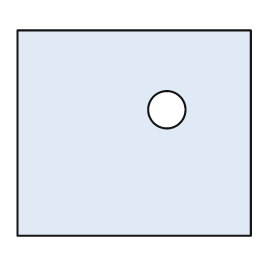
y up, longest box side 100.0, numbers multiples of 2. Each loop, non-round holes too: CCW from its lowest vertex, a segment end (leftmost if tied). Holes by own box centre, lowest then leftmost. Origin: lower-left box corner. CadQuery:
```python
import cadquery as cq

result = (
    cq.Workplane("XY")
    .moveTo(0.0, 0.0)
    .lineTo(100.0, 0.0)
    .lineTo(100.0, 88.0)
    .lineTo(0.0, 88.0)
    .close()
    .moveTo(64.0, 54.0)
    .circle(8.0)
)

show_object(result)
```